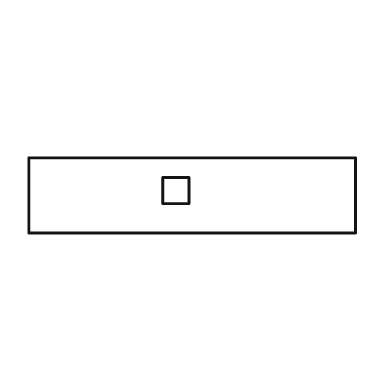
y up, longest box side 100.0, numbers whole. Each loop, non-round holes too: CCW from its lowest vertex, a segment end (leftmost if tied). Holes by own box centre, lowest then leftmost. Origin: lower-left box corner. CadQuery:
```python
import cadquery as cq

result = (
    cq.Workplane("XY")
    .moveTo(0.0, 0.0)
    .lineTo(100.0, 0.0)
    .lineTo(100.0, 23.0)
    .lineTo(0.0, 23.0)
    .close()
    .moveTo(41.0, 9.0)
    .lineTo(49.0, 9.0)
    .lineTo(49.0, 17.0)
    .lineTo(41.0, 17.0)
    .close()
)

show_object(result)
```